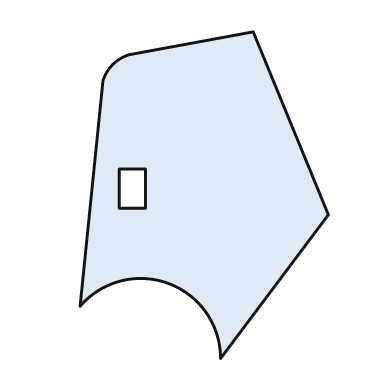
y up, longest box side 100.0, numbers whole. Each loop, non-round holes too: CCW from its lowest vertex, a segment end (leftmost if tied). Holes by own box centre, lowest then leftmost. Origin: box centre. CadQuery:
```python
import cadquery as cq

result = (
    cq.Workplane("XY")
    .moveTo(5.0, -50.0)
    .lineTo(38.0, -6.0)
    .lineTo(15.0, 50.0)
    .lineTo(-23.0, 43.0)
    .threePointArc((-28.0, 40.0), (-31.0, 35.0))
    .lineTo(-38.0, -34.0)
    .threePointArc((-11.0, -27.0), (5.0, -50.0))
    .close()
    .moveTo(-26.0, -4.0)
    .lineTo(-18.0, -4.0)
    .lineTo(-18.0, 8.0)
    .lineTo(-26.0, 8.0)
    .close()
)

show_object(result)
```